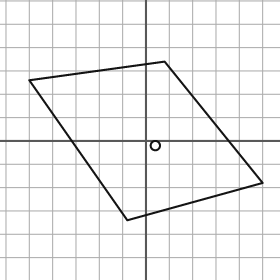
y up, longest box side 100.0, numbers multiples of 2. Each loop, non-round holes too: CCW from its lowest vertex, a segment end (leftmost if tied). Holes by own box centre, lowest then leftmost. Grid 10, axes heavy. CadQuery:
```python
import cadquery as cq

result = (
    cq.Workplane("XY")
    .moveTo(-8.0, -34.0)
    .lineTo(50.0, -18.0)
    .lineTo(8.0, 34.0)
    .lineTo(-50.0, 26.0)
    .close()
    .moveTo(4.0, -2.0)
    .circle(2.0)
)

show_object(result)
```